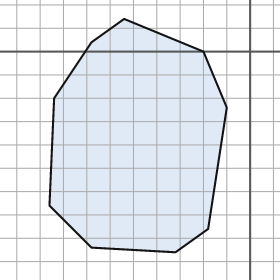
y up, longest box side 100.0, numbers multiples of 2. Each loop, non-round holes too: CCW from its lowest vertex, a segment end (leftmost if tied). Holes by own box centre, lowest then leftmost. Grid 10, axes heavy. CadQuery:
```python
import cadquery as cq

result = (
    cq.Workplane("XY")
    .moveTo(-32.0, -86.0)
    .lineTo(-18.0, -76.0)
    .lineTo(-10.0, -24.0)
    .lineTo(-20.0, 0.0)
    .lineTo(-54.0, 14.0)
    .lineTo(-68.0, 4.0)
    .lineTo(-84.0, -20.0)
    .lineTo(-86.0, -66.0)
    .lineTo(-68.0, -84.0)
    .close()
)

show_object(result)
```